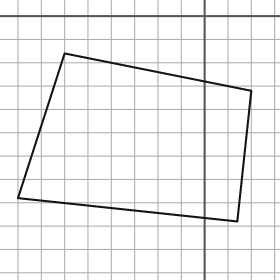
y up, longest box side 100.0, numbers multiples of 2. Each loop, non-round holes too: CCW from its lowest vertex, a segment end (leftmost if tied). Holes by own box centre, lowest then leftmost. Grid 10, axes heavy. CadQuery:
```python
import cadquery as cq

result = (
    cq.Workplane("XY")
    .moveTo(14.0, -88.0)
    .lineTo(20.0, -32.0)
    .lineTo(-60.0, -16.0)
    .lineTo(-80.0, -78.0)
    .close()
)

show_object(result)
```